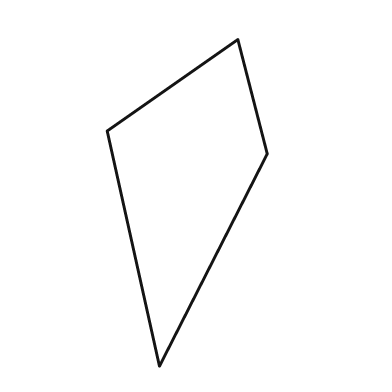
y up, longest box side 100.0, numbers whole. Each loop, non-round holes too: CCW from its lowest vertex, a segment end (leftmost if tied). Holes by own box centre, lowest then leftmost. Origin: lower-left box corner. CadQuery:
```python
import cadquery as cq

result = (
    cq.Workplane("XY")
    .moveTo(16.0, 0.0)
    .lineTo(49.0, 65.0)
    .lineTo(40.0, 100.0)
    .lineTo(0.0, 72.0)
    .close()
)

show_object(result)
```